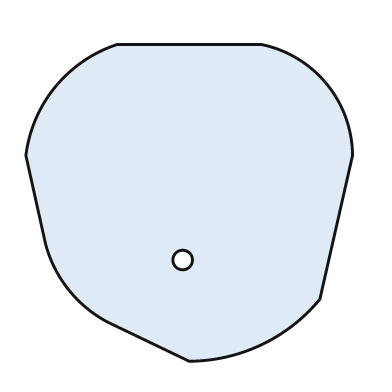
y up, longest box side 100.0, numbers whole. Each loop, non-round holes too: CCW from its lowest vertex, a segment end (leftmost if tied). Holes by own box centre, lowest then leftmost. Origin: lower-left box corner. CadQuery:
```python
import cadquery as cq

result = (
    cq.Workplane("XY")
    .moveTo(50.0, 0.0)
    .threePointArc((72.0, 5.0), (90.0, 19.0))
    .lineTo(100.0, 63.0)
    .threePointArc((92.0, 85.0), (72.0, 97.0))
    .lineTo(28.0, 97.0)
    .threePointArc((9.0, 84.0), (0.0, 63.0))
    .lineTo(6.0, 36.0)
    .threePointArc((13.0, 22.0), (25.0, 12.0))
    .close()
    .moveTo(48.0, 31.0)
    .circle(3.0)
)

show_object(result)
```